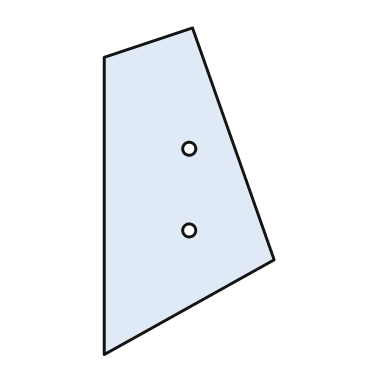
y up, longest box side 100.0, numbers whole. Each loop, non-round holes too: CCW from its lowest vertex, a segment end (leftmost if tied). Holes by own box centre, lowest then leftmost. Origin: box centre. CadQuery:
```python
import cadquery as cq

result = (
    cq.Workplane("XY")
    .moveTo(-26.0, -50.0)
    .lineTo(26.0, -21.0)
    .lineTo(1.0, 50.0)
    .lineTo(-26.0, 41.0)
    .close()
    .moveTo(0.0, -12.0)
    .circle(2.0)
    .moveTo(0.0, 13.0)
    .circle(2.0)
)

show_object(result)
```